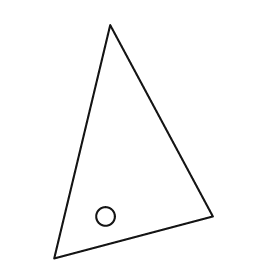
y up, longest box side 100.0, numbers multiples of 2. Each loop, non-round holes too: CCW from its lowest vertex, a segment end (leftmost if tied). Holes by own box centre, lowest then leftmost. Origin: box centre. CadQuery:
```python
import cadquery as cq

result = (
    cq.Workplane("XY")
    .moveTo(-34.0, -50.0)
    .lineTo(34.0, -32.0)
    .lineTo(-10.0, 50.0)
    .close()
    .moveTo(-12.0, -32.0)
    .circle(4.0)
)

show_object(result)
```